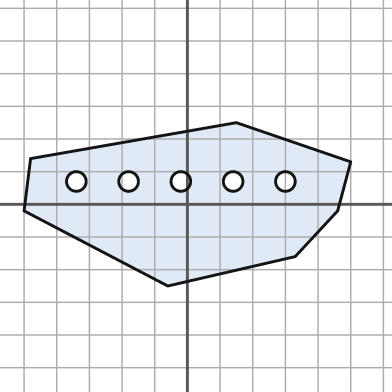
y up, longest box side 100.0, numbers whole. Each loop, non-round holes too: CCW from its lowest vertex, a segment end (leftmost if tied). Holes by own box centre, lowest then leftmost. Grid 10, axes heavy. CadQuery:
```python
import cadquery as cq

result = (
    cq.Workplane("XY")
    .moveTo(-6.0, -25.0)
    .lineTo(33.0, -16.0)
    .lineTo(46.0, -2.0)
    .lineTo(50.0, 13.0)
    .lineTo(15.0, 25.0)
    .lineTo(-48.0, 14.0)
    .lineTo(-50.0, -2.0)
    .close()
    .moveTo(-34.0, 7.0)
    .circle(3.0)
    .moveTo(-18.0, 7.0)
    .circle(3.0)
    .moveTo(-2.0, 7.0)
    .circle(3.0)
    .moveTo(14.0, 7.0)
    .circle(3.0)
    .moveTo(30.0, 7.0)
    .circle(3.0)
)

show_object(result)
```